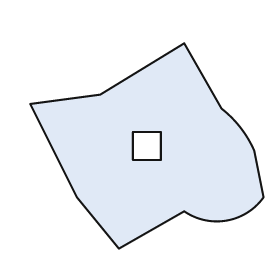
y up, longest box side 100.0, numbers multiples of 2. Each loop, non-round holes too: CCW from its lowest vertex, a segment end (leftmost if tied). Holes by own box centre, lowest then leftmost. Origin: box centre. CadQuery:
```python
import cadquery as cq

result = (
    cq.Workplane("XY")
    .moveTo(-12.0, -44.0)
    .lineTo(16.0, -28.0)
    .threePointArc((34.0, -32.0), (50.0, -22.0))
    .lineTo(46.0, -2.0)
    .threePointArc((40.0, 8.0), (32.0, 16.0))
    .lineTo(16.0, 44.0)
    .lineTo(-20.0, 22.0)
    .lineTo(-50.0, 18.0)
    .lineTo(-30.0, -22.0)
    .close()
    .moveTo(-6.0, -6.0)
    .lineTo(6.0, -6.0)
    .lineTo(6.0, 6.0)
    .lineTo(-6.0, 6.0)
    .close()
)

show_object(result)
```